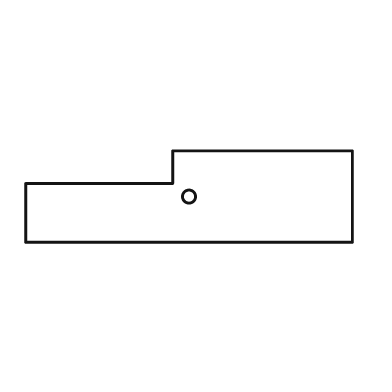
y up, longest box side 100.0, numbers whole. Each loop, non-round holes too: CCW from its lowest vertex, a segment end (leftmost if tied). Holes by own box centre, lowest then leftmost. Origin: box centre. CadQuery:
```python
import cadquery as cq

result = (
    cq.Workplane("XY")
    .moveTo(-50.0, -14.0)
    .lineTo(50.0, -14.0)
    .lineTo(50.0, 14.0)
    .lineTo(-5.0, 14.0)
    .lineTo(-5.0, 4.0)
    .lineTo(-50.0, 4.0)
    .close()
    .moveTo(0.0, 0.0)
    .circle(2.0)
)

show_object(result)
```